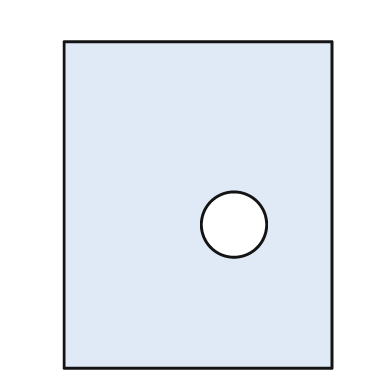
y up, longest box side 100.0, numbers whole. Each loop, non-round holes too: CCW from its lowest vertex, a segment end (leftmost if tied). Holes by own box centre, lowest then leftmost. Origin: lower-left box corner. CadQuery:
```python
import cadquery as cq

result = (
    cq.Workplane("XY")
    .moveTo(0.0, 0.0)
    .lineTo(82.0, 0.0)
    .lineTo(82.0, 100.0)
    .lineTo(0.0, 100.0)
    .close()
    .moveTo(52.0, 44.0)
    .circle(10.0)
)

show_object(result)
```